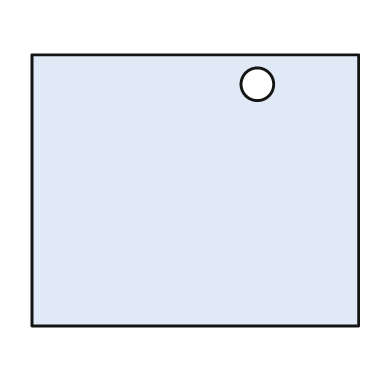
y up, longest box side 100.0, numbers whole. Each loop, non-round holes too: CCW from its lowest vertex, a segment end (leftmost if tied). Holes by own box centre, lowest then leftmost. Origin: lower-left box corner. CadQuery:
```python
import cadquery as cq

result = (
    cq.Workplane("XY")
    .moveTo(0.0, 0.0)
    .lineTo(100.0, 0.0)
    .lineTo(100.0, 83.0)
    .lineTo(0.0, 83.0)
    .close()
    .moveTo(69.0, 74.0)
    .circle(5.0)
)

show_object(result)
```